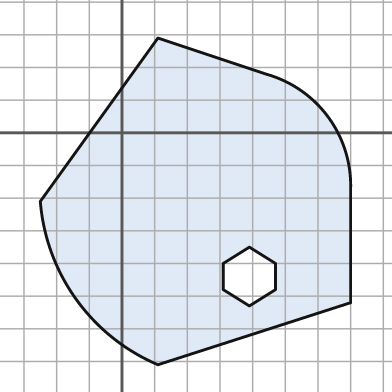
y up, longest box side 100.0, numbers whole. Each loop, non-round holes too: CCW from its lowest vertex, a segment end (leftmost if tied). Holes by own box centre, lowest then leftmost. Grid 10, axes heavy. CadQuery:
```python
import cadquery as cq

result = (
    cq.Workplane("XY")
    .moveTo(11.0, -71.0)
    .lineTo(70.0, -52.0)
    .lineTo(70.0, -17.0)
    .threePointArc((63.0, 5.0), (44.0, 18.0))
    .lineTo(11.0, 29.0)
    .lineTo(-25.0, -21.0)
    .threePointArc((-14.0, -51.0), (11.0, -71.0))
    .close()
    .moveTo(39.0, -53.0)
    .lineTo(47.0, -48.0)
    .lineTo(47.0, -40.0)
    .lineTo(39.0, -35.0)
    .lineTo(31.0, -40.0)
    .lineTo(31.0, -48.0)
    .close()
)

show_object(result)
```